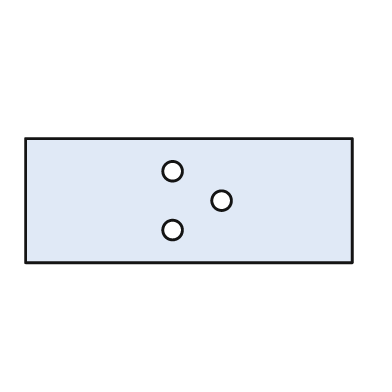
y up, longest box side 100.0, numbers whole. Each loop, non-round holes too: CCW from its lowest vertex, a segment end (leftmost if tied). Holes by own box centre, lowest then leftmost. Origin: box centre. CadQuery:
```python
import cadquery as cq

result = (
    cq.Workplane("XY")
    .moveTo(-50.0, -19.0)
    .lineTo(50.0, -19.0)
    .lineTo(50.0, 19.0)
    .lineTo(-50.0, 19.0)
    .close()
    .moveTo(-5.0, -9.0)
    .circle(3.0)
    .moveTo(10.0, 0.0)
    .circle(3.0)
    .moveTo(-5.0, 9.0)
    .circle(3.0)
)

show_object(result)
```